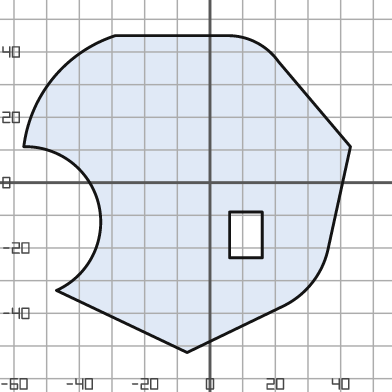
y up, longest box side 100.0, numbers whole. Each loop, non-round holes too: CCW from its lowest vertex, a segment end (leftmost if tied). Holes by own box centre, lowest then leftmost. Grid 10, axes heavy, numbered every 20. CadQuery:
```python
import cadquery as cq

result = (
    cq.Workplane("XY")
    .moveTo(-7.0, -52.0)
    .lineTo(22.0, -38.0)
    .threePointArc((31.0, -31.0), (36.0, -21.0))
    .lineTo(43.0, 11.0)
    .lineTo(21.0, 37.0)
    .threePointArc((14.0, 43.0), (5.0, 45.0))
    .lineTo(-29.0, 45.0)
    .threePointArc((-48.0, 32.0), (-57.0, 11.0))
    .threePointArc((-34.0, -7.0), (-47.0, -33.0))
    .close()
    .moveTo(6.0, -23.0)
    .lineTo(16.0, -23.0)
    .lineTo(16.0, -9.0)
    .lineTo(6.0, -9.0)
    .close()
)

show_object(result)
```